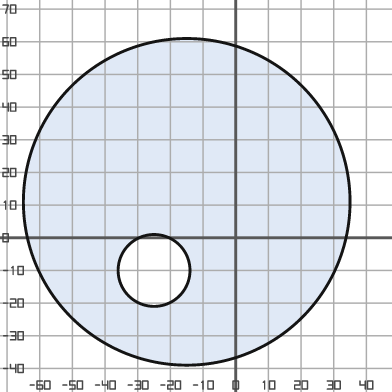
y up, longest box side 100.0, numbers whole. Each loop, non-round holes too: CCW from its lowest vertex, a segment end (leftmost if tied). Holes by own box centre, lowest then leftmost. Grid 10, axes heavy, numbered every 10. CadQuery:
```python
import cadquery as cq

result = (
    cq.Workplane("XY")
    .moveTo(-15.0, 11.0)
    .circle(50.0)
    .moveTo(-25.0, -10.0)
    .circle(11.0)
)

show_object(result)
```